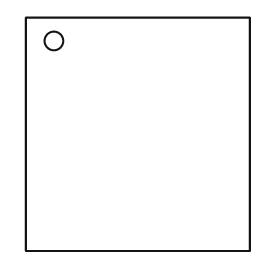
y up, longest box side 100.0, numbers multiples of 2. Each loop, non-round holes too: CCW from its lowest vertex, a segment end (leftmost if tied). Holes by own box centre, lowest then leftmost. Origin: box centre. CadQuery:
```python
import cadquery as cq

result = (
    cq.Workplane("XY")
    .moveTo(-48.0, -50.0)
    .lineTo(48.0, -50.0)
    .lineTo(48.0, 50.0)
    .lineTo(-48.0, 50.0)
    .close()
    .moveTo(-36.0, 40.0)
    .circle(4.0)
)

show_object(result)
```